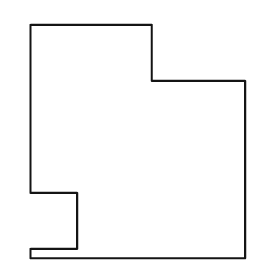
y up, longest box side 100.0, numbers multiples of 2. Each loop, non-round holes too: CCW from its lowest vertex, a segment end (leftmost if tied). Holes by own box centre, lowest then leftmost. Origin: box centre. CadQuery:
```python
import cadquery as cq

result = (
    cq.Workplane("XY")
    .moveTo(-46.0, -50.0)
    .lineTo(46.0, -50.0)
    .lineTo(46.0, 26.0)
    .lineTo(6.0, 26.0)
    .lineTo(6.0, 50.0)
    .lineTo(-46.0, 50.0)
    .lineTo(-46.0, -22.0)
    .lineTo(-26.0, -22.0)
    .lineTo(-26.0, -46.0)
    .lineTo(-46.0, -46.0)
    .close()
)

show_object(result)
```